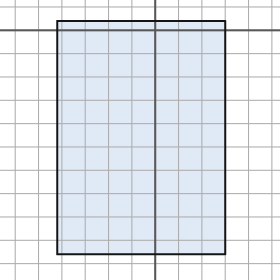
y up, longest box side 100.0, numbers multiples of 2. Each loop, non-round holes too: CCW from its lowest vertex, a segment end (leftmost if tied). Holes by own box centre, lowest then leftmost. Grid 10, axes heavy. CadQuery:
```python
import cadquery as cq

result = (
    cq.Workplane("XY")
    .moveTo(-42.0, -96.0)
    .lineTo(30.0, -96.0)
    .lineTo(30.0, 4.0)
    .lineTo(-42.0, 4.0)
    .close()
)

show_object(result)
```